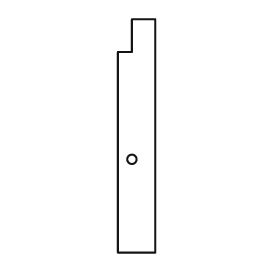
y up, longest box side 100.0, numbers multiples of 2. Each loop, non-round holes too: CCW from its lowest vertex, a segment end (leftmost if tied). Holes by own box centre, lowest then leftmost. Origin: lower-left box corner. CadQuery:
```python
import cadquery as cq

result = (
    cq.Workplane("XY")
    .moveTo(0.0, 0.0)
    .lineTo(16.0, 0.0)
    .lineTo(16.0, 100.0)
    .lineTo(6.0, 100.0)
    .lineTo(6.0, 86.0)
    .lineTo(0.0, 86.0)
    .close()
    .moveTo(6.0, 40.0)
    .circle(2.0)
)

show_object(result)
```